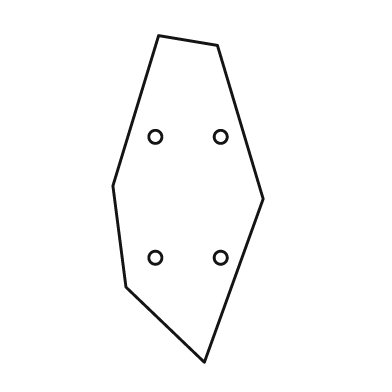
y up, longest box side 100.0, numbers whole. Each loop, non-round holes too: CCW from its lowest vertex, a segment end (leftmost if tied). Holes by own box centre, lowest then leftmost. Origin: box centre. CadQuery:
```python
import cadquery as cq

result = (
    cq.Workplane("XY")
    .moveTo(5.0, -50.0)
    .lineTo(23.0, 0.0)
    .lineTo(9.0, 47.0)
    .lineTo(-9.0, 50.0)
    .lineTo(-23.0, 4.0)
    .lineTo(-19.0, -27.0)
    .close()
    .moveTo(-10.0, -18.0)
    .circle(2.0)
    .moveTo(10.0, -18.0)
    .circle(2.0)
    .moveTo(-10.0, 19.0)
    .circle(2.0)
    .moveTo(10.0, 19.0)
    .circle(2.0)
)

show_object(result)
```